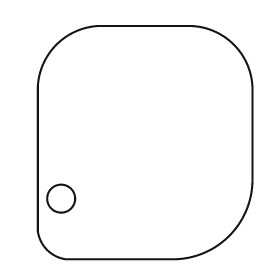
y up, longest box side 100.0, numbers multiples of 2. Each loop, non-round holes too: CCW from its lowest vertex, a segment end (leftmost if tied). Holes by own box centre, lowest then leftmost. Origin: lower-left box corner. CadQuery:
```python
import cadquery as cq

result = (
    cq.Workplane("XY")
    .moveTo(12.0, 0.0)
    .lineTo(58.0, 0.0)
    .threePointArc((82.0, 10.0), (92.0, 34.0))
    .lineTo(92.0, 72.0)
    .threePointArc((84.0, 92.0), (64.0, 100.0))
    .lineTo(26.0, 100.0)
    .threePointArc((8.0, 92.0), (0.0, 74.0))
    .lineTo(0.0, 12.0)
    .threePointArc((4.0, 4.0), (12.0, 0.0))
    .close()
    .moveTo(10.0, 26.0)
    .circle(6.0)
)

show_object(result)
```